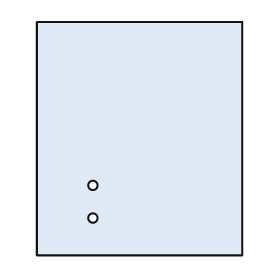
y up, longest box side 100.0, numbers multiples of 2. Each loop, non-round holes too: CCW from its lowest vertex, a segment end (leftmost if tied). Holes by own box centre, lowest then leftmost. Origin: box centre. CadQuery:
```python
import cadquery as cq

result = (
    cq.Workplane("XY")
    .moveTo(-44.0, -50.0)
    .lineTo(44.0, -50.0)
    .lineTo(44.0, 50.0)
    .lineTo(-44.0, 50.0)
    .close()
    .moveTo(-20.0, -34.0)
    .circle(2.0)
    .moveTo(-20.0, -20.0)
    .circle(2.0)
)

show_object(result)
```